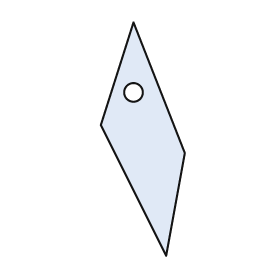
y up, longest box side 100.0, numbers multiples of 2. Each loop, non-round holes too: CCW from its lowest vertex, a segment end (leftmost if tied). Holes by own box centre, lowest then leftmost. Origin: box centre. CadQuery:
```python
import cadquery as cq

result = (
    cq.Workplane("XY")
    .moveTo(10.0, -50.0)
    .lineTo(18.0, -6.0)
    .lineTo(-4.0, 50.0)
    .lineTo(-18.0, 6.0)
    .close()
    .moveTo(-4.0, 20.0)
    .circle(4.0)
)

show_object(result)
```